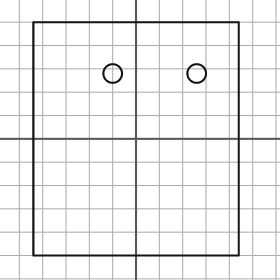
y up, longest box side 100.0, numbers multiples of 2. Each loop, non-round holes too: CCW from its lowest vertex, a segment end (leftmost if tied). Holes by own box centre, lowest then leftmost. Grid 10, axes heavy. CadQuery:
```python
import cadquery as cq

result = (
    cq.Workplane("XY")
    .moveTo(-44.0, -50.0)
    .lineTo(44.0, -50.0)
    .lineTo(44.0, 50.0)
    .lineTo(-44.0, 50.0)
    .close()
    .moveTo(-10.0, 28.0)
    .circle(4.0)
    .moveTo(26.0, 28.0)
    .circle(4.0)
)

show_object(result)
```